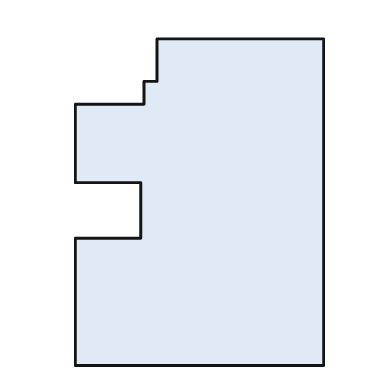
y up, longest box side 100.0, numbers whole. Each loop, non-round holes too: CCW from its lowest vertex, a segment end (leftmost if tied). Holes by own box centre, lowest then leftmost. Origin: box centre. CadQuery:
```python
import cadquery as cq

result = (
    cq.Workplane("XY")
    .moveTo(-38.0, -50.0)
    .lineTo(38.0, -50.0)
    .lineTo(38.0, 50.0)
    .lineTo(-13.0, 50.0)
    .lineTo(-13.0, 37.0)
    .lineTo(-17.0, 37.0)
    .lineTo(-17.0, 30.0)
    .lineTo(-38.0, 30.0)
    .lineTo(-38.0, 6.0)
    .lineTo(-18.0, 6.0)
    .lineTo(-18.0, -11.0)
    .lineTo(-38.0, -11.0)
    .close()
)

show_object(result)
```